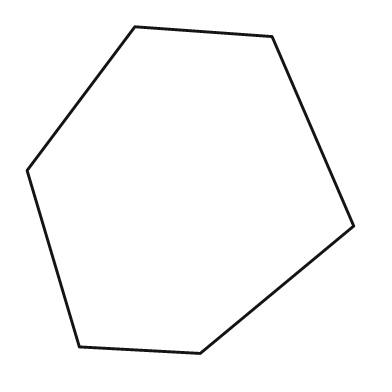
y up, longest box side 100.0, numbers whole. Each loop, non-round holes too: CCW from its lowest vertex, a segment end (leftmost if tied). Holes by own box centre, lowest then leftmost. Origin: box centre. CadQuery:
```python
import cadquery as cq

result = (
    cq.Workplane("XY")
    .moveTo(3.0, -50.0)
    .lineTo(50.0, -11.0)
    .lineTo(25.0, 47.0)
    .lineTo(-17.0, 50.0)
    .lineTo(-50.0, 6.0)
    .lineTo(-34.0, -48.0)
    .close()
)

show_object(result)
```